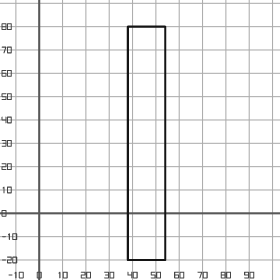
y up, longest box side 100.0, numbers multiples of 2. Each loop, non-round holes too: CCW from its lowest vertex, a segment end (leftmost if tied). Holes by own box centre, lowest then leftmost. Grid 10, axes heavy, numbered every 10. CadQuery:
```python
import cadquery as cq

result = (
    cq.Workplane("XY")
    .moveTo(38.0, -20.0)
    .lineTo(54.0, -20.0)
    .lineTo(54.0, 80.0)
    .lineTo(38.0, 80.0)
    .close()
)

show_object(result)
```